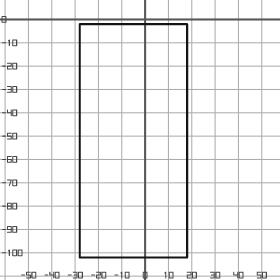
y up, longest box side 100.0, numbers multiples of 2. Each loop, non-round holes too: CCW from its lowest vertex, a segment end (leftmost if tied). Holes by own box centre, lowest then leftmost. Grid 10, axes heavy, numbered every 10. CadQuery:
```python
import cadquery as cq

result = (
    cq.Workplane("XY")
    .moveTo(-28.0, -102.0)
    .lineTo(18.0, -102.0)
    .lineTo(18.0, -2.0)
    .lineTo(-28.0, -2.0)
    .close()
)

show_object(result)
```